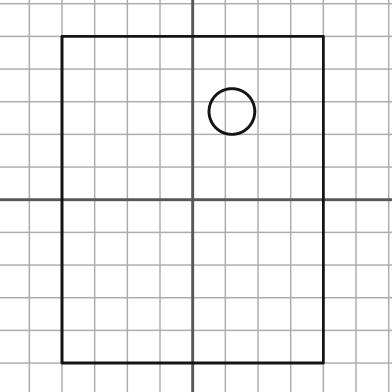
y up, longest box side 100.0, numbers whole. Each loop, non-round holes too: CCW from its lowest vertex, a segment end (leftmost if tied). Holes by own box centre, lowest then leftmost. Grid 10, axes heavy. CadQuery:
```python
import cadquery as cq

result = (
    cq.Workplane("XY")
    .moveTo(-40.0, -50.0)
    .lineTo(40.0, -50.0)
    .lineTo(40.0, 50.0)
    .lineTo(-40.0, 50.0)
    .close()
    .moveTo(12.0, 27.0)
    .circle(7.0)
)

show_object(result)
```